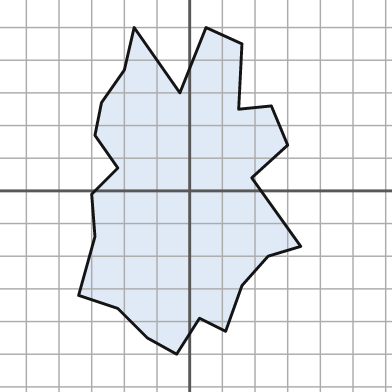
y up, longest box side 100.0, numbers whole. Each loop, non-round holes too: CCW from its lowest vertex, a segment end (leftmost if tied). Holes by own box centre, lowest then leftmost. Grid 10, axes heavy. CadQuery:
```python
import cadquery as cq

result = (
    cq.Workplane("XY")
    .moveTo(-4.0, -50.0)
    .lineTo(3.0, -39.0)
    .lineTo(11.0, -43.0)
    .lineTo(16.0, -29.0)
    .lineTo(24.0, -20.0)
    .lineTo(34.0, -17.0)
    .lineTo(19.0, 4.0)
    .lineTo(30.0, 14.0)
    .lineTo(25.0, 26.0)
    .lineTo(15.0, 25.0)
    .lineTo(16.0, 45.0)
    .lineTo(5.0, 50.0)
    .lineTo(-3.0, 30.0)
    .lineTo(-17.0, 50.0)
    .lineTo(-20.0, 37.0)
    .lineTo(-27.0, 27.0)
    .lineTo(-29.0, 17.0)
    .lineTo(-22.0, 7.0)
    .lineTo(-30.0, -1.0)
    .lineTo(-29.0, -14.0)
    .lineTo(-34.0, -32.0)
    .lineTo(-22.0, -36.0)
    .lineTo(-13.0, -45.0)
    .close()
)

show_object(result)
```